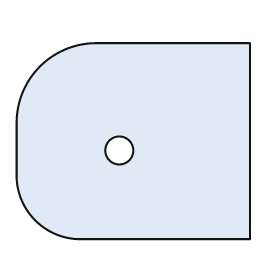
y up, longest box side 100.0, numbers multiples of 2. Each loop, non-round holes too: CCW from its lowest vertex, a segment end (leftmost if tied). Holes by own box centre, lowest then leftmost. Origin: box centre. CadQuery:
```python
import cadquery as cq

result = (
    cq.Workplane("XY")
    .moveTo(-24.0, -42.0)
    .lineTo(50.0, -42.0)
    .lineTo(50.0, 42.0)
    .lineTo(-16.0, 42.0)
    .threePointArc((-40.0, 32.0), (-50.0, 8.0))
    .lineTo(-50.0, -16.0)
    .threePointArc((-42.0, -34.0), (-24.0, -42.0))
    .close()
    .moveTo(-6.0, -4.0)
    .circle(6.0)
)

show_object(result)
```